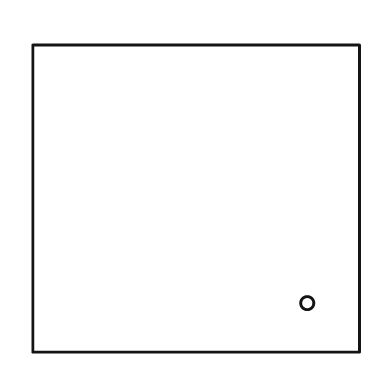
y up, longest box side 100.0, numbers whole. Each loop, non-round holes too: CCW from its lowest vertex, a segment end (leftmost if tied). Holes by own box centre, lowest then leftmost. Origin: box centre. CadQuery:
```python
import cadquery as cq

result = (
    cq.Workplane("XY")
    .moveTo(-50.0, -47.0)
    .lineTo(50.0, -47.0)
    .lineTo(50.0, 47.0)
    .lineTo(-50.0, 47.0)
    .close()
    .moveTo(34.0, -32.0)
    .circle(2.0)
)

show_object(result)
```